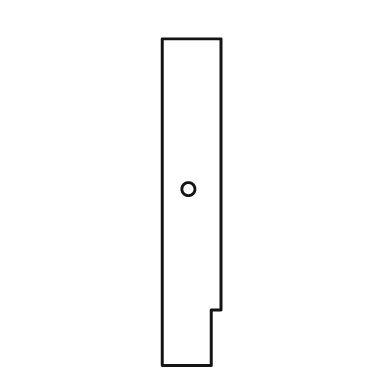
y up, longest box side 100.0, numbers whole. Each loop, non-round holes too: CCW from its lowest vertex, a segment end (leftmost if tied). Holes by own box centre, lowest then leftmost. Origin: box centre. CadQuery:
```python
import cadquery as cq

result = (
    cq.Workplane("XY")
    .moveTo(-9.0, -50.0)
    .lineTo(6.0, -50.0)
    .lineTo(6.0, -33.0)
    .lineTo(9.0, -33.0)
    .lineTo(9.0, 50.0)
    .lineTo(-9.0, 50.0)
    .close()
    .moveTo(-1.0, 4.0)
    .circle(2.0)
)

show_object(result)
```